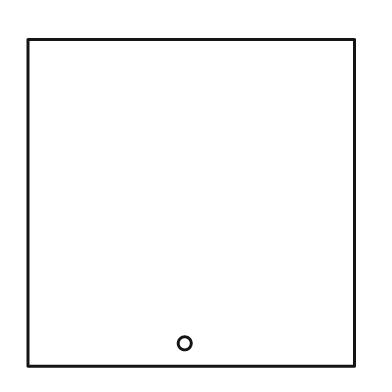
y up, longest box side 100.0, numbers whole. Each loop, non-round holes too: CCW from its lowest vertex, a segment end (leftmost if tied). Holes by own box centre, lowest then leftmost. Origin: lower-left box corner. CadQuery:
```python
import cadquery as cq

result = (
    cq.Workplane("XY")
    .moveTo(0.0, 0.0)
    .lineTo(100.0, 0.0)
    .lineTo(100.0, 100.0)
    .lineTo(0.0, 100.0)
    .close()
    .moveTo(48.0, 7.0)
    .circle(2.0)
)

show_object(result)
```